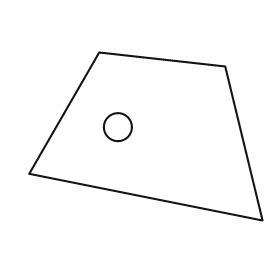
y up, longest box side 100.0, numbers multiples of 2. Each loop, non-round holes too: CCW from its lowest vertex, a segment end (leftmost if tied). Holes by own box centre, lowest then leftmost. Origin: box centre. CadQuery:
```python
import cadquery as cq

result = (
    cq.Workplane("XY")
    .moveTo(50.0, -36.0)
    .lineTo(34.0, 30.0)
    .lineTo(-20.0, 36.0)
    .lineTo(-50.0, -16.0)
    .close()
    .moveTo(-12.0, 4.0)
    .circle(6.0)
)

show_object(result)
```